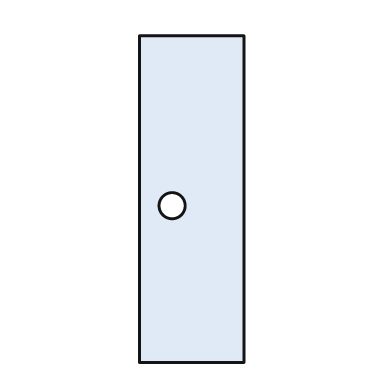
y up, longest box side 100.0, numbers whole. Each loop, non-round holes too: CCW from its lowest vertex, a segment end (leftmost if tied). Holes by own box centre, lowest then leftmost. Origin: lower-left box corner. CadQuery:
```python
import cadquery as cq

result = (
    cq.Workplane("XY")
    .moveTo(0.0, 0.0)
    .lineTo(32.0, 0.0)
    .lineTo(32.0, 100.0)
    .lineTo(0.0, 100.0)
    .close()
    .moveTo(10.0, 48.0)
    .circle(4.0)
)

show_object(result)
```